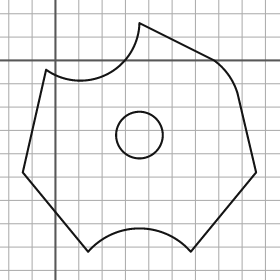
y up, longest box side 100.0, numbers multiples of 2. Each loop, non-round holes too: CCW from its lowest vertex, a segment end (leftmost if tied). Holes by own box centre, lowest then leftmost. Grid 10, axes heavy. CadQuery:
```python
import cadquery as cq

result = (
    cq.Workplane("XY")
    .moveTo(14.0, -82.0)
    .threePointArc((36.0, -72.0), (58.0, -82.0))
    .lineTo(86.0, -48.0)
    .lineTo(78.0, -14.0)
    .threePointArc((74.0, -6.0), (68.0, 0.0))
    .lineTo(36.0, 16.0)
    .threePointArc((22.0, -6.0), (-4.0, -4.0))
    .lineTo(-14.0, -48.0)
    .close()
    .moveTo(36.0, -32.0)
    .circle(10.0)
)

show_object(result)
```